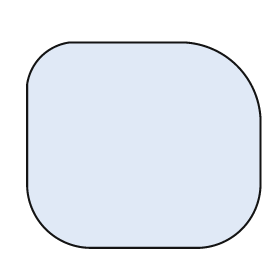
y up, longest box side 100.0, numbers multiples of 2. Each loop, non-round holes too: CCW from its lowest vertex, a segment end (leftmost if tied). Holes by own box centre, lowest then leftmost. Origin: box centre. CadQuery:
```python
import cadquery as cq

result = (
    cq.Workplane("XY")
    .moveTo(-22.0, -44.0)
    .lineTo(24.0, -44.0)
    .threePointArc((42.0, -36.0), (50.0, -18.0))
    .lineTo(50.0, 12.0)
    .threePointArc((40.0, 34.0), (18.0, 44.0))
    .lineTo(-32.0, 44.0)
    .threePointArc((-44.0, 38.0), (-50.0, 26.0))
    .lineTo(-50.0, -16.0)
    .threePointArc((-42.0, -36.0), (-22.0, -44.0))
    .close()
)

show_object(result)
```